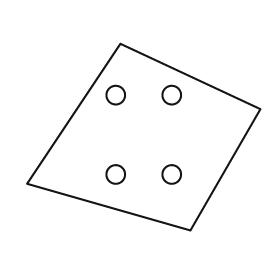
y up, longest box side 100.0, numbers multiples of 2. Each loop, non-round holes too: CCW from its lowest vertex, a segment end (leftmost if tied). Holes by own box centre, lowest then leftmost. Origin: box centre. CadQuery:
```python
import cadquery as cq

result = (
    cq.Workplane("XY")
    .moveTo(20.0, -40.0)
    .lineTo(50.0, 12.0)
    .lineTo(-10.0, 40.0)
    .lineTo(-50.0, -20.0)
    .close()
    .moveTo(-12.0, -16.0)
    .circle(4.0)
    .moveTo(12.0, -16.0)
    .circle(4.0)
    .moveTo(-12.0, 18.0)
    .circle(4.0)
    .moveTo(12.0, 18.0)
    .circle(4.0)
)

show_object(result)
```